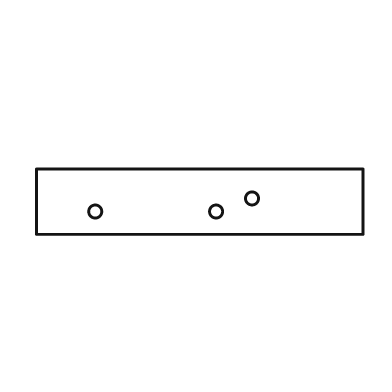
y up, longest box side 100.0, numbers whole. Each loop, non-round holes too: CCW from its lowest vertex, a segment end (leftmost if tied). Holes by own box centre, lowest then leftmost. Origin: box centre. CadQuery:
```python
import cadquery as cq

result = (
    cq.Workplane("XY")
    .moveTo(-50.0, -10.0)
    .lineTo(50.0, -10.0)
    .lineTo(50.0, 10.0)
    .lineTo(-50.0, 10.0)
    .close()
    .moveTo(-32.0, -3.0)
    .circle(2.0)
    .moveTo(5.0, -3.0)
    .circle(2.0)
    .moveTo(16.0, 1.0)
    .circle(2.0)
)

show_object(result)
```